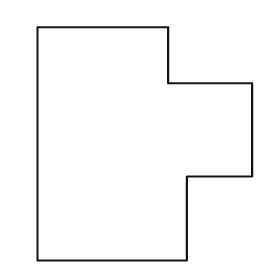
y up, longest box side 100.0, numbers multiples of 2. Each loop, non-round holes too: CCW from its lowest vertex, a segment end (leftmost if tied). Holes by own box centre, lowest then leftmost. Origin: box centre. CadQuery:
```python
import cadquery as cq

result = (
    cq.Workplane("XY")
    .moveTo(-46.0, -50.0)
    .lineTo(18.0, -50.0)
    .lineTo(18.0, -14.0)
    .lineTo(46.0, -14.0)
    .lineTo(46.0, 26.0)
    .lineTo(10.0, 26.0)
    .lineTo(10.0, 50.0)
    .lineTo(-46.0, 50.0)
    .close()
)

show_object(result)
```